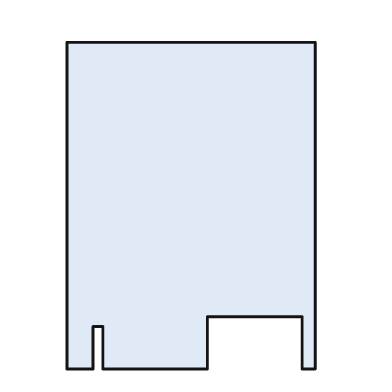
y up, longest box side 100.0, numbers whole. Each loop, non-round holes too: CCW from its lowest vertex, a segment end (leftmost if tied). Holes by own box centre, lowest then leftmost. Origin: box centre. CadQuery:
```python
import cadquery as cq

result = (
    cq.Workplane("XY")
    .moveTo(-38.0, -50.0)
    .lineTo(-30.0, -50.0)
    .lineTo(-30.0, -37.0)
    .lineTo(-27.0, -37.0)
    .lineTo(-27.0, -50.0)
    .lineTo(5.0, -50.0)
    .lineTo(5.0, -34.0)
    .lineTo(34.0, -34.0)
    .lineTo(34.0, -50.0)
    .lineTo(38.0, -50.0)
    .lineTo(38.0, 50.0)
    .lineTo(-38.0, 50.0)
    .close()
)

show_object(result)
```